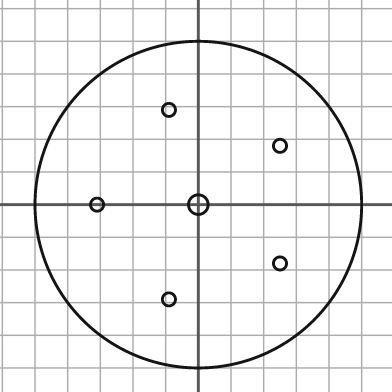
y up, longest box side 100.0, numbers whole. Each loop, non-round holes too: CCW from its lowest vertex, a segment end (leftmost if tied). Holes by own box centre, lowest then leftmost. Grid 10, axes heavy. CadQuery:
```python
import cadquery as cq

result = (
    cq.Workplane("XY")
    .moveTo(0.0, 0.0)
    .circle(50.0)
    .moveTo(-9.0, -29.0)
    .circle(2.0)
    .moveTo(25.0, -18.0)
    .circle(2.0)
    .moveTo(-31.0, 0.0)
    .circle(2.0)
    .moveTo(0.0, 0.0)
    .circle(3.0)
    .moveTo(25.0, 18.0)
    .circle(2.0)
    .moveTo(-9.0, 29.0)
    .circle(2.0)
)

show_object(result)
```